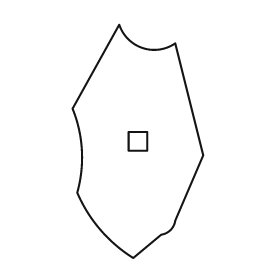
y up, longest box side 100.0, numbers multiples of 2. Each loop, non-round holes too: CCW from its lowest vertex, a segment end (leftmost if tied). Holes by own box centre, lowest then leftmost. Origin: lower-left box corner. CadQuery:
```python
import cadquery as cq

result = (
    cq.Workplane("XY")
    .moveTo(26.0, 0.0)
    .lineTo(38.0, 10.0)
    .threePointArc((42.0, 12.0), (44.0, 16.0))
    .lineTo(56.0, 44.0)
    .lineTo(44.0, 92.0)
    .threePointArc((30.0, 90.0), (20.0, 100.0))
    .lineTo(0.0, 64.0)
    .threePointArc((4.0, 46.0), (2.0, 28.0))
    .threePointArc((12.0, 12.0), (26.0, 0.0))
    .close()
    .moveTo(24.0, 46.0)
    .lineTo(32.0, 46.0)
    .lineTo(32.0, 54.0)
    .lineTo(24.0, 54.0)
    .close()
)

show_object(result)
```